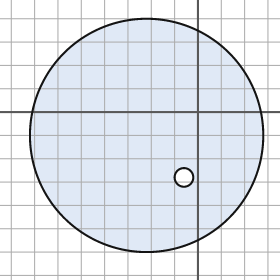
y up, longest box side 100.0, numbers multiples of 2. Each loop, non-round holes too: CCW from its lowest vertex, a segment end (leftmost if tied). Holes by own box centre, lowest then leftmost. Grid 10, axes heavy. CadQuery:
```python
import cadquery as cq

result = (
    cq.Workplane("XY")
    .moveTo(-22.0, -10.0)
    .circle(50.0)
    .moveTo(-6.0, -28.0)
    .circle(4.0)
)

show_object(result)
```